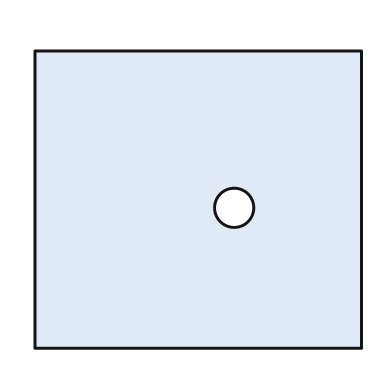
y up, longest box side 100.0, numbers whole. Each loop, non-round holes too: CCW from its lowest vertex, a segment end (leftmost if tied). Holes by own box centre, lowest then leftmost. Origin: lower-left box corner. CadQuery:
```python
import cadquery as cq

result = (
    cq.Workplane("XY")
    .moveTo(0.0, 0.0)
    .lineTo(100.0, 0.0)
    .lineTo(100.0, 91.0)
    .lineTo(0.0, 91.0)
    .close()
    .moveTo(61.0, 43.0)
    .circle(6.0)
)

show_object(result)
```